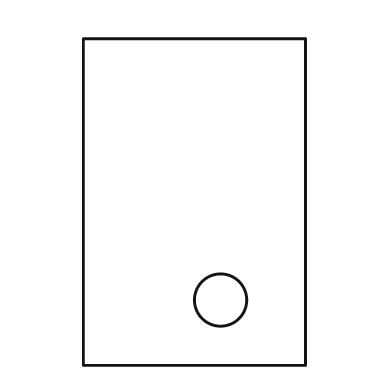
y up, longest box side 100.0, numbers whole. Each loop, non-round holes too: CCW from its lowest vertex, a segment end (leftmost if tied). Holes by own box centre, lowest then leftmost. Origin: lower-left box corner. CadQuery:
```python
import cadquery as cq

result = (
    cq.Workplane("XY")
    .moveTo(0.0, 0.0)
    .lineTo(68.0, 0.0)
    .lineTo(68.0, 100.0)
    .lineTo(0.0, 100.0)
    .close()
    .moveTo(42.0, 20.0)
    .circle(8.0)
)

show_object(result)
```